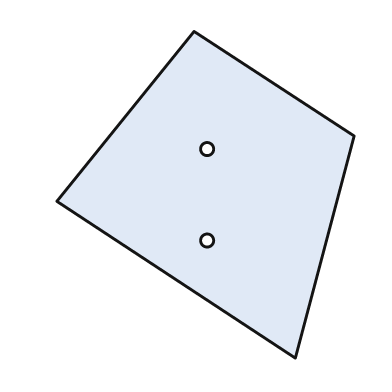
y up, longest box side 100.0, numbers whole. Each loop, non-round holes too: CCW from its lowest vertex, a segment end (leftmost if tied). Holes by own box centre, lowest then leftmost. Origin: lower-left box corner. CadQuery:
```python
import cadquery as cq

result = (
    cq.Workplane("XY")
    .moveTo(73.0, 0.0)
    .lineTo(91.0, 68.0)
    .lineTo(42.0, 100.0)
    .lineTo(0.0, 48.0)
    .close()
    .moveTo(46.0, 36.0)
    .circle(2.0)
    .moveTo(46.0, 64.0)
    .circle(2.0)
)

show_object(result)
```